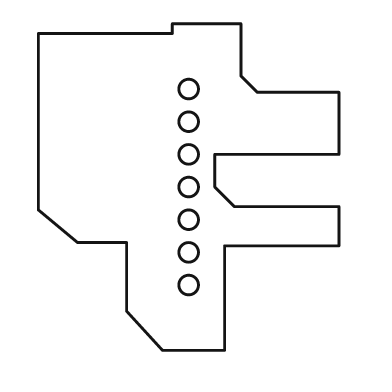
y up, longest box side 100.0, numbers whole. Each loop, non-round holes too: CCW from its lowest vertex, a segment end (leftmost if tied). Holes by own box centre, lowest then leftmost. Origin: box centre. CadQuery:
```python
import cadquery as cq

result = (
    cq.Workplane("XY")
    .moveTo(-8.0, -50.0)
    .lineTo(11.0, -50.0)
    .lineTo(11.0, -18.0)
    .lineTo(46.0, -18.0)
    .lineTo(46.0, -6.0)
    .lineTo(14.0, -6.0)
    .lineTo(8.0, 0.0)
    .lineTo(8.0, 10.0)
    .lineTo(46.0, 10.0)
    .lineTo(46.0, 29.0)
    .lineTo(21.0, 29.0)
    .lineTo(16.0, 34.0)
    .lineTo(16.0, 50.0)
    .lineTo(-5.0, 50.0)
    .lineTo(-5.0, 47.0)
    .lineTo(-46.0, 47.0)
    .lineTo(-46.0, -7.0)
    .lineTo(-34.0, -17.0)
    .lineTo(-19.0, -17.0)
    .lineTo(-19.0, -38.0)
    .close()
    .moveTo(0.0, -30.0)
    .circle(3.0)
    .moveTo(0.0, -20.0)
    .circle(3.0)
    .moveTo(0.0, -10.0)
    .circle(3.0)
    .moveTo(0.0, 0.0)
    .circle(3.0)
    .moveTo(0.0, 10.0)
    .circle(3.0)
    .moveTo(0.0, 20.0)
    .circle(3.0)
    .moveTo(0.0, 30.0)
    .circle(3.0)
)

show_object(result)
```